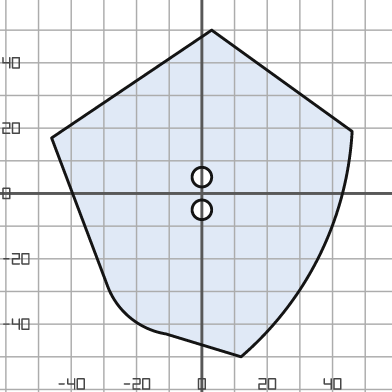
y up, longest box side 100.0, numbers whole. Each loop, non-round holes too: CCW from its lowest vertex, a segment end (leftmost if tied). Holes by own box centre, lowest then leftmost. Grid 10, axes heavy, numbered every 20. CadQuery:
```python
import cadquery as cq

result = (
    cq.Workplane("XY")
    .moveTo(12.0, -50.0)
    .threePointArc((36.0, -19.0), (46.0, 19.0))
    .lineTo(3.0, 50.0)
    .lineTo(-46.0, 17.0)
    .lineTo(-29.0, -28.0)
    .threePointArc((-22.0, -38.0), (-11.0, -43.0))
    .close()
    .moveTo(0.0, -5.0)
    .circle(3.0)
    .moveTo(0.0, 5.0)
    .circle(3.0)
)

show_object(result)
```